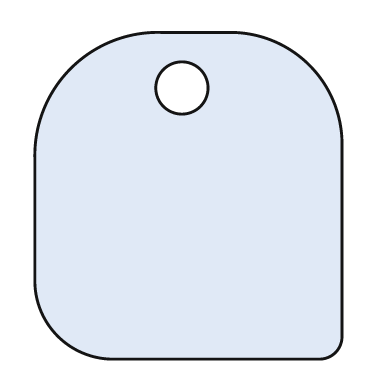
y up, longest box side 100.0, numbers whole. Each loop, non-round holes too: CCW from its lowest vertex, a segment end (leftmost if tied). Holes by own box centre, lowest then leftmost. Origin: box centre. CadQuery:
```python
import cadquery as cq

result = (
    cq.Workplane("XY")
    .moveTo(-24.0, -50.0)
    .lineTo(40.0, -50.0)
    .threePointArc((45.0, -48.0), (47.0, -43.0))
    .lineTo(47.0, 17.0)
    .threePointArc((37.0, 40.0), (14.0, 50.0))
    .lineTo(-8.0, 50.0)
    .threePointArc((-36.0, 39.0), (-47.0, 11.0))
    .lineTo(-47.0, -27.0)
    .threePointArc((-40.0, -43.0), (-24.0, -50.0))
    .close()
    .moveTo(-2.0, 33.0)
    .circle(8.0)
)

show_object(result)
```